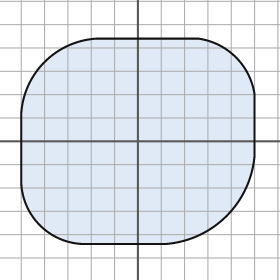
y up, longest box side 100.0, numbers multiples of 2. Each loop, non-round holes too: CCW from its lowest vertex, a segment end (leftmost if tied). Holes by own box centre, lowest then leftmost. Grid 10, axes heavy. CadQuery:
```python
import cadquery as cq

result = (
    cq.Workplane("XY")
    .moveTo(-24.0, -44.0)
    .lineTo(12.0, -44.0)
    .threePointArc((38.0, -32.0), (50.0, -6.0))
    .lineTo(50.0, 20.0)
    .threePointArc((42.0, 36.0), (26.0, 44.0))
    .lineTo(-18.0, 44.0)
    .threePointArc((-40.0, 34.0), (-50.0, 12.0))
    .lineTo(-50.0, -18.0)
    .threePointArc((-42.0, -36.0), (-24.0, -44.0))
    .close()
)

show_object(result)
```